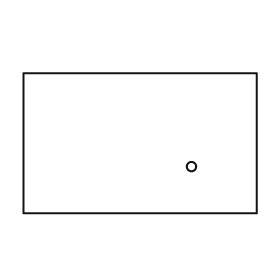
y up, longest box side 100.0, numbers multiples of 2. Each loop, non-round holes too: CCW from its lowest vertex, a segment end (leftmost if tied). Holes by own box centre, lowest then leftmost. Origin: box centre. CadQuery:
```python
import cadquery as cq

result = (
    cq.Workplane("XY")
    .moveTo(-50.0, -30.0)
    .lineTo(50.0, -30.0)
    .lineTo(50.0, 30.0)
    .lineTo(-50.0, 30.0)
    .close()
    .moveTo(22.0, -10.0)
    .circle(2.0)
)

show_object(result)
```